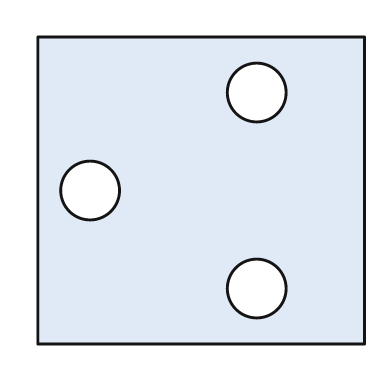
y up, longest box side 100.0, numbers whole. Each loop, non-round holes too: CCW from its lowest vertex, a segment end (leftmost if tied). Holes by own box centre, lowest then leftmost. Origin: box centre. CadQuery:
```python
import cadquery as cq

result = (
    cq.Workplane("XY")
    .moveTo(-50.0, -47.0)
    .lineTo(50.0, -47.0)
    .lineTo(50.0, 47.0)
    .lineTo(-50.0, 47.0)
    .close()
    .moveTo(17.0, -30.0)
    .circle(9.0)
    .moveTo(-34.0, 0.0)
    .circle(9.0)
    .moveTo(17.0, 30.0)
    .circle(9.0)
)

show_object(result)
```